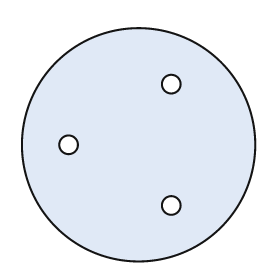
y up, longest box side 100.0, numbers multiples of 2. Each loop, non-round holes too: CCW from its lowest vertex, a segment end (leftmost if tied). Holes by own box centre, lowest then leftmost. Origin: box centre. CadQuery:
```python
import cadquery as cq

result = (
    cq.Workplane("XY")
    .moveTo(0.0, 0.0)
    .circle(50.0)
    .moveTo(14.0, -26.0)
    .circle(4.0)
    .moveTo(-30.0, 0.0)
    .circle(4.0)
    .moveTo(14.0, 26.0)
    .circle(4.0)
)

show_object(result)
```